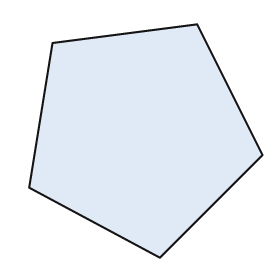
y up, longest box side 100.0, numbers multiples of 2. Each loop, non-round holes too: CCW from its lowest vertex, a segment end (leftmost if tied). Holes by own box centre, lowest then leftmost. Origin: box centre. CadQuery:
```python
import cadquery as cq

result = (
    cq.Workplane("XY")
    .moveTo(6.0, -50.0)
    .lineTo(50.0, -6.0)
    .lineTo(22.0, 50.0)
    .lineTo(-40.0, 42.0)
    .lineTo(-50.0, -20.0)
    .close()
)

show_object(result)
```